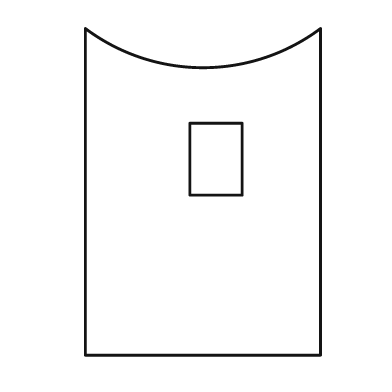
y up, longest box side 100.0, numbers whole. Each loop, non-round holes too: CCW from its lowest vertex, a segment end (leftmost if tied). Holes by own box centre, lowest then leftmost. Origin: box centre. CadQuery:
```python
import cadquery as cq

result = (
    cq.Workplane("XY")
    .moveTo(-36.0, -50.0)
    .lineTo(36.0, -50.0)
    .lineTo(36.0, 50.0)
    .threePointArc((0.0, 38.0), (-36.0, 50.0))
    .close()
    .moveTo(-4.0, -1.0)
    .lineTo(12.0, -1.0)
    .lineTo(12.0, 21.0)
    .lineTo(-4.0, 21.0)
    .close()
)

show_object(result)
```